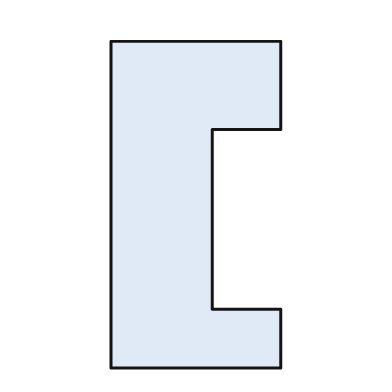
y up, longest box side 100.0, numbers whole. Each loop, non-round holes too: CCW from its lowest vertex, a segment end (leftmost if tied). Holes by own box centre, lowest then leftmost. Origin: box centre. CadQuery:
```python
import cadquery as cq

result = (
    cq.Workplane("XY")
    .moveTo(-26.0, -50.0)
    .lineTo(26.0, -50.0)
    .lineTo(26.0, -32.0)
    .lineTo(5.0, -32.0)
    .lineTo(5.0, 23.0)
    .lineTo(26.0, 23.0)
    .lineTo(26.0, 50.0)
    .lineTo(-26.0, 50.0)
    .close()
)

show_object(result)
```